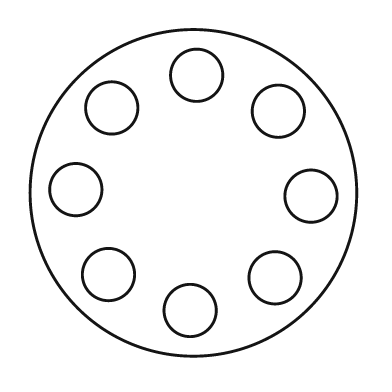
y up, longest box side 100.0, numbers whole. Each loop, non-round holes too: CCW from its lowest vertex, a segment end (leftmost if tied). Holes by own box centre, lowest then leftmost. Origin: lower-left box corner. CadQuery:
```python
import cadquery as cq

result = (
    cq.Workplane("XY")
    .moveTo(50.0, 50.0)
    .circle(50.0)
    .moveTo(49.0, 14.0)
    .circle(8.0)
    .moveTo(75.0, 24.0)
    .circle(8.0)
    .moveTo(24.0, 25.0)
    .circle(8.0)
    .moveTo(86.0, 49.0)
    .circle(8.0)
    .moveTo(14.0, 51.0)
    .circle(8.0)
    .moveTo(76.0, 75.0)
    .circle(8.0)
    .moveTo(25.0, 76.0)
    .circle(8.0)
    .moveTo(51.0, 86.0)
    .circle(8.0)
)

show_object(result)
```